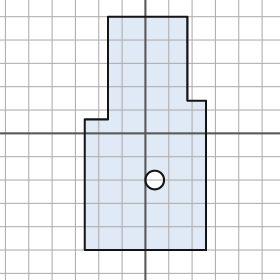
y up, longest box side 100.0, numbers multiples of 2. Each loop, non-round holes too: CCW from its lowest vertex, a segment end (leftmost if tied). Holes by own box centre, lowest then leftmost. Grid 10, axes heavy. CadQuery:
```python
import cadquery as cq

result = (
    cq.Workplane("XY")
    .moveTo(-26.0, -50.0)
    .lineTo(26.0, -50.0)
    .lineTo(26.0, 14.0)
    .lineTo(18.0, 14.0)
    .lineTo(18.0, 50.0)
    .lineTo(-16.0, 50.0)
    .lineTo(-16.0, 6.0)
    .lineTo(-26.0, 6.0)
    .close()
    .moveTo(4.0, -20.0)
    .circle(4.0)
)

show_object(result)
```